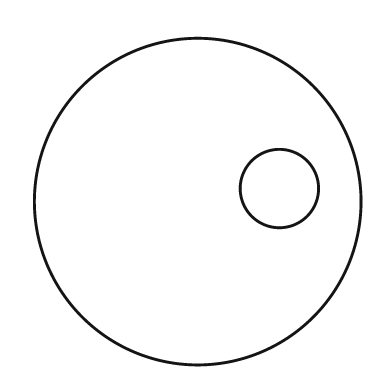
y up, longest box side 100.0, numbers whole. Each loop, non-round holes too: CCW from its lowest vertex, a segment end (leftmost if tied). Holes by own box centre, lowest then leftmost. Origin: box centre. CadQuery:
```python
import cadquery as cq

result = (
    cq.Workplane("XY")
    .moveTo(0.0, 0.0)
    .circle(50.0)
    .moveTo(25.0, 4.0)
    .circle(12.0)
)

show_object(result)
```